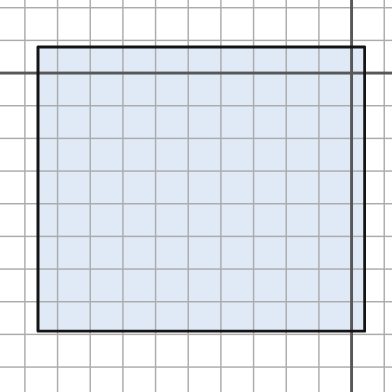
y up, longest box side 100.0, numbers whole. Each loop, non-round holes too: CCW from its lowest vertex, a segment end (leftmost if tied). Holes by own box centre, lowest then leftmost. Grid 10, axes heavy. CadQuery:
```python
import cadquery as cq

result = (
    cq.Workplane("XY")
    .moveTo(-96.0, -79.0)
    .lineTo(4.0, -79.0)
    .lineTo(4.0, 8.0)
    .lineTo(-96.0, 8.0)
    .close()
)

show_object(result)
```